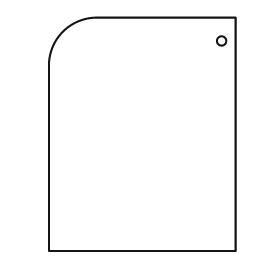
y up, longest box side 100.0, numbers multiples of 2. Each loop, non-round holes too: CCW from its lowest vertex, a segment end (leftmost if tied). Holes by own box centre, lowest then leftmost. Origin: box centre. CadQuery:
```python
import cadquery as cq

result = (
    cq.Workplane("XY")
    .moveTo(-40.0, -50.0)
    .lineTo(40.0, -50.0)
    .lineTo(40.0, 50.0)
    .lineTo(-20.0, 50.0)
    .threePointArc((-34.0, 44.0), (-40.0, 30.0))
    .close()
    .moveTo(34.0, 40.0)
    .circle(2.0)
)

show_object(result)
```